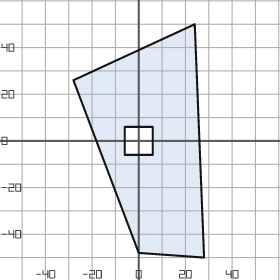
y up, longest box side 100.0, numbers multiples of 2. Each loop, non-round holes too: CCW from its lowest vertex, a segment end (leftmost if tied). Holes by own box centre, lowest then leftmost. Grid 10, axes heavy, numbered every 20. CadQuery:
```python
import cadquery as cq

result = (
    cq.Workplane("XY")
    .moveTo(28.0, -50.0)
    .lineTo(24.0, 50.0)
    .lineTo(-28.0, 26.0)
    .lineTo(0.0, -48.0)
    .close()
    .moveTo(-6.0, -6.0)
    .lineTo(6.0, -6.0)
    .lineTo(6.0, 6.0)
    .lineTo(-6.0, 6.0)
    .close()
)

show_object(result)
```